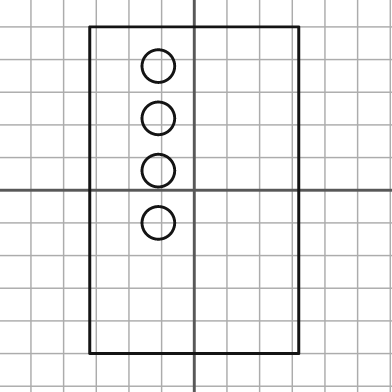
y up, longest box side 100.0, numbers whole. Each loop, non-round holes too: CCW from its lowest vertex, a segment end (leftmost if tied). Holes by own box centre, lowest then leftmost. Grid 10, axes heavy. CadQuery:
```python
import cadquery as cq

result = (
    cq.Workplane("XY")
    .moveTo(-32.0, -50.0)
    .lineTo(32.0, -50.0)
    .lineTo(32.0, 50.0)
    .lineTo(-32.0, 50.0)
    .close()
    .moveTo(-11.0, -10.0)
    .circle(5.0)
    .moveTo(-11.0, 6.0)
    .circle(5.0)
    .moveTo(-11.0, 22.0)
    .circle(5.0)
    .moveTo(-11.0, 38.0)
    .circle(5.0)
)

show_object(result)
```